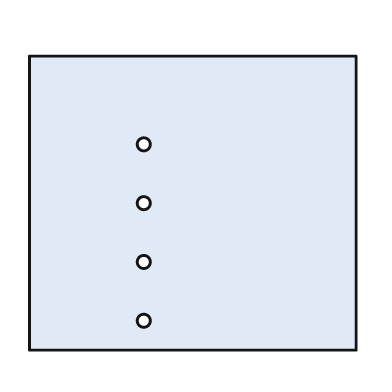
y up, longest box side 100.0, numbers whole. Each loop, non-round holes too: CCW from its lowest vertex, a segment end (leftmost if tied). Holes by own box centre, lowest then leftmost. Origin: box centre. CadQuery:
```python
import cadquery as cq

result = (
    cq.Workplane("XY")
    .moveTo(-50.0, -45.0)
    .lineTo(50.0, -45.0)
    .lineTo(50.0, 45.0)
    .lineTo(-50.0, 45.0)
    .close()
    .moveTo(-15.0, -36.0)
    .circle(2.0)
    .moveTo(-15.0, -18.0)
    .circle(2.0)
    .moveTo(-15.0, 0.0)
    .circle(2.0)
    .moveTo(-15.0, 18.0)
    .circle(2.0)
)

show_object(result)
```